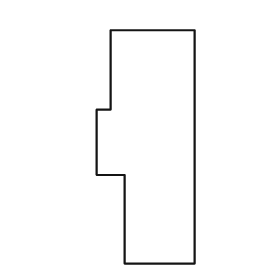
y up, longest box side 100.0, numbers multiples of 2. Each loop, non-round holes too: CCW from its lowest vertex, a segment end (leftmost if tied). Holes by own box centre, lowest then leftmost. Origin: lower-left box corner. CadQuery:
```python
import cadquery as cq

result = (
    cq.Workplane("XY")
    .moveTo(12.0, 0.0)
    .lineTo(42.0, 0.0)
    .lineTo(42.0, 100.0)
    .lineTo(6.0, 100.0)
    .lineTo(6.0, 66.0)
    .lineTo(0.0, 66.0)
    .lineTo(0.0, 38.0)
    .lineTo(12.0, 38.0)
    .close()
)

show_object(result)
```